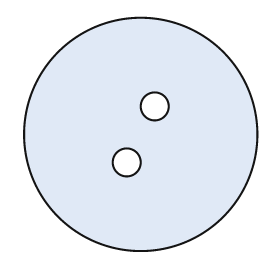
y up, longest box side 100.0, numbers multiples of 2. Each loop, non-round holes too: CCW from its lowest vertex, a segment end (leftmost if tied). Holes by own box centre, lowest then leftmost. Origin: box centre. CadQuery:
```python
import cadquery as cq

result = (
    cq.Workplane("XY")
    .moveTo(0.0, 0.0)
    .circle(50.0)
    .moveTo(-6.0, -12.0)
    .circle(6.0)
    .moveTo(6.0, 12.0)
    .circle(6.0)
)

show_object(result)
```